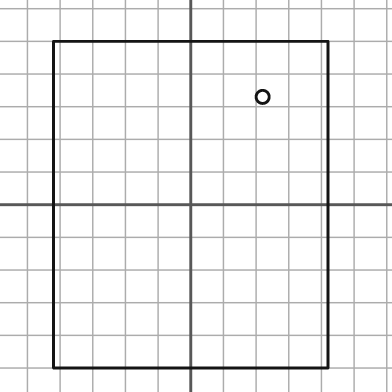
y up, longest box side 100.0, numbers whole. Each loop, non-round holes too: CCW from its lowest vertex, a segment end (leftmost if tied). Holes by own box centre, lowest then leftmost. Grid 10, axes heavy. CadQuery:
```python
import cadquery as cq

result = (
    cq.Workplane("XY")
    .moveTo(-42.0, -50.0)
    .lineTo(42.0, -50.0)
    .lineTo(42.0, 50.0)
    .lineTo(-42.0, 50.0)
    .close()
    .moveTo(22.0, 33.0)
    .circle(2.0)
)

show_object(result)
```